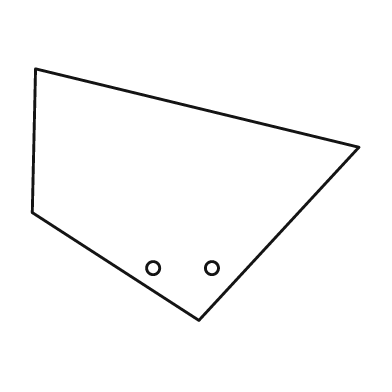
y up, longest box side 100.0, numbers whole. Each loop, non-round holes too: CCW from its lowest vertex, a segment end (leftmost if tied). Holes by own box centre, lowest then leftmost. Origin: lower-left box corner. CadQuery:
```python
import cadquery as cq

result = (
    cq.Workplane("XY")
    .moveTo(51.0, 0.0)
    .lineTo(100.0, 53.0)
    .lineTo(1.0, 77.0)
    .lineTo(0.0, 33.0)
    .close()
    .moveTo(37.0, 16.0)
    .circle(2.0)
    .moveTo(55.0, 16.0)
    .circle(2.0)
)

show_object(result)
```